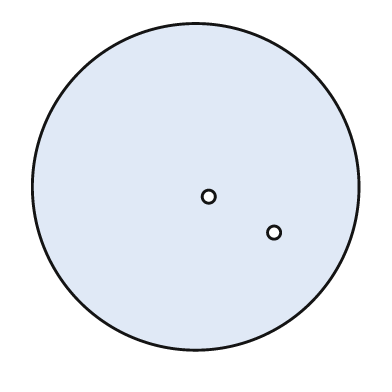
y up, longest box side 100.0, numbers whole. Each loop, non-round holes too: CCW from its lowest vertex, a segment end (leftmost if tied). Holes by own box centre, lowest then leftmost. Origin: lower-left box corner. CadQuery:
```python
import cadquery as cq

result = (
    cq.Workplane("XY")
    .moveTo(50.0, 50.0)
    .circle(50.0)
    .moveTo(74.0, 36.0)
    .circle(2.0)
    .moveTo(54.0, 47.0)
    .circle(2.0)
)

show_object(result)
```